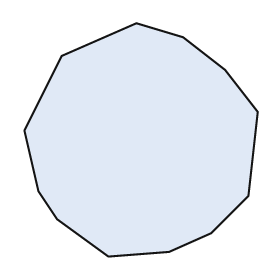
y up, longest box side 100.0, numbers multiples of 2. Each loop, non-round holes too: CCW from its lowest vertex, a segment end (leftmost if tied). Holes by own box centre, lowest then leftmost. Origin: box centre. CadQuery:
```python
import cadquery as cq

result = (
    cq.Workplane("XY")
    .moveTo(-14.0, -50.0)
    .lineTo(12.0, -48.0)
    .lineTo(30.0, -40.0)
    .lineTo(46.0, -24.0)
    .lineTo(50.0, 12.0)
    .lineTo(36.0, 30.0)
    .lineTo(18.0, 44.0)
    .lineTo(-2.0, 50.0)
    .lineTo(-34.0, 36.0)
    .lineTo(-50.0, 4.0)
    .lineTo(-44.0, -22.0)
    .lineTo(-36.0, -34.0)
    .close()
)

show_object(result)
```